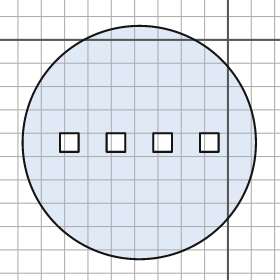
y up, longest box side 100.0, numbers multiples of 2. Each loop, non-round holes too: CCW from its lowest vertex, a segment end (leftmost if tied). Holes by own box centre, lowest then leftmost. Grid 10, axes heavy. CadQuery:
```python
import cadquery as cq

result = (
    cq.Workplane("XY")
    .moveTo(-38.0, -44.0)
    .circle(50.0)
    .moveTo(-72.0, -48.0)
    .lineTo(-64.0, -48.0)
    .lineTo(-64.0, -40.0)
    .lineTo(-72.0, -40.0)
    .close()
    .moveTo(-52.0, -48.0)
    .lineTo(-44.0, -48.0)
    .lineTo(-44.0, -40.0)
    .lineTo(-52.0, -40.0)
    .close()
    .moveTo(-32.0, -48.0)
    .lineTo(-24.0, -48.0)
    .lineTo(-24.0, -40.0)
    .lineTo(-32.0, -40.0)
    .close()
    .moveTo(-12.0, -48.0)
    .lineTo(-4.0, -48.0)
    .lineTo(-4.0, -40.0)
    .lineTo(-12.0, -40.0)
    .close()
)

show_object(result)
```